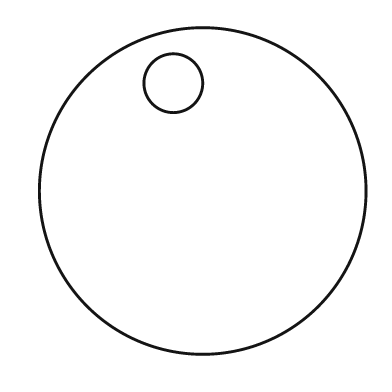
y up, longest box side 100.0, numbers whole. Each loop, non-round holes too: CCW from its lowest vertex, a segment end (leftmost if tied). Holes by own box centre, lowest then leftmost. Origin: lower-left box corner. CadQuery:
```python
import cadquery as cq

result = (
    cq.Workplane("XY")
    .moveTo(50.0, 50.0)
    .circle(50.0)
    .moveTo(41.0, 83.0)
    .circle(9.0)
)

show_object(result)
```